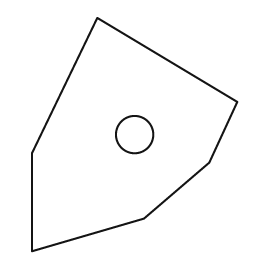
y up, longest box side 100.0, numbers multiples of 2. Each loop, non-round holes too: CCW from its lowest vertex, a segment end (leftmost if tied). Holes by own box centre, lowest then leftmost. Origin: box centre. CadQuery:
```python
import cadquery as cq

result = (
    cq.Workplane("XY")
    .moveTo(-44.0, -50.0)
    .lineTo(4.0, -36.0)
    .lineTo(32.0, -12.0)
    .lineTo(44.0, 14.0)
    .lineTo(-16.0, 50.0)
    .lineTo(-44.0, -8.0)
    .close()
    .moveTo(0.0, 0.0)
    .circle(8.0)
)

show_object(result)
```